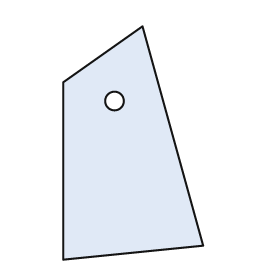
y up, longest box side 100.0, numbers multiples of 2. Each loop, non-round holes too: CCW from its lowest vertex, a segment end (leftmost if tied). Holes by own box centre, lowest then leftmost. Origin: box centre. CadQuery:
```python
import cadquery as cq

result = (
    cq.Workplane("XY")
    .moveTo(-30.0, -50.0)
    .lineTo(30.0, -44.0)
    .lineTo(4.0, 50.0)
    .lineTo(-30.0, 26.0)
    .close()
    .moveTo(-8.0, 18.0)
    .circle(4.0)
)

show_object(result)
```